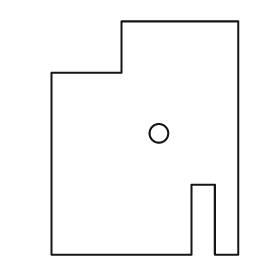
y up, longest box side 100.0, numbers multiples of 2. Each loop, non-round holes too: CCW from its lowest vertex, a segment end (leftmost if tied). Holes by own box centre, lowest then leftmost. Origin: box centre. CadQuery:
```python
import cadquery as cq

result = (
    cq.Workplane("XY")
    .moveTo(-40.0, -50.0)
    .lineTo(20.0, -50.0)
    .lineTo(20.0, -20.0)
    .lineTo(30.0, -20.0)
    .lineTo(30.0, -50.0)
    .lineTo(40.0, -50.0)
    .lineTo(40.0, 50.0)
    .lineTo(-10.0, 50.0)
    .lineTo(-10.0, 28.0)
    .lineTo(-40.0, 28.0)
    .close()
    .moveTo(6.0, 2.0)
    .circle(4.0)
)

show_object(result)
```